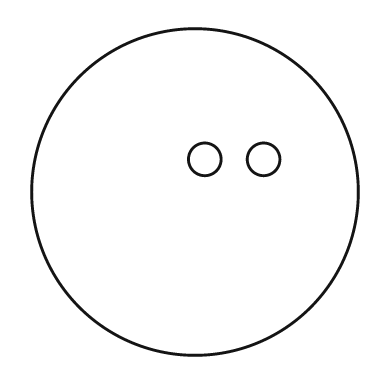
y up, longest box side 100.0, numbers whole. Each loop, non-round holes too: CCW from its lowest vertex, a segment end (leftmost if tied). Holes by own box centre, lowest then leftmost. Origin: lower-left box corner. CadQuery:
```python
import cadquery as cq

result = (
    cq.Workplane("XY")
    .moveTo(50.0, 50.0)
    .circle(50.0)
    .moveTo(53.0, 60.0)
    .circle(5.0)
    .moveTo(71.0, 60.0)
    .circle(5.0)
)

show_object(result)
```